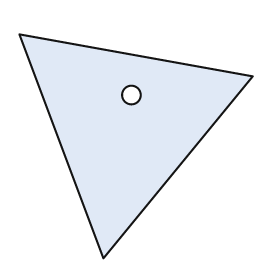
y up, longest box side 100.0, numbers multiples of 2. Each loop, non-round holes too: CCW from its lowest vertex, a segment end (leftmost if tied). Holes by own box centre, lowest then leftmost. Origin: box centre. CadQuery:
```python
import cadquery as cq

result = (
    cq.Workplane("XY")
    .moveTo(-14.0, -48.0)
    .lineTo(50.0, 30.0)
    .lineTo(-50.0, 48.0)
    .close()
    .moveTo(-2.0, 22.0)
    .circle(4.0)
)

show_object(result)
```